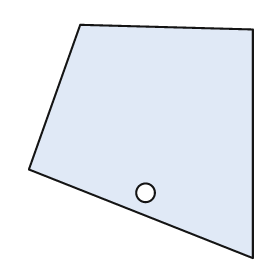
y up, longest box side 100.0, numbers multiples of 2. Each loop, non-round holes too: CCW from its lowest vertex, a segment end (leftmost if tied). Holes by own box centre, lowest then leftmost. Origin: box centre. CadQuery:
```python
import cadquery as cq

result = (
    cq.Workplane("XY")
    .moveTo(48.0, -50.0)
    .lineTo(48.0, 48.0)
    .lineTo(-26.0, 50.0)
    .lineTo(-48.0, -12.0)
    .close()
    .moveTo(2.0, -22.0)
    .circle(4.0)
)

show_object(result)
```